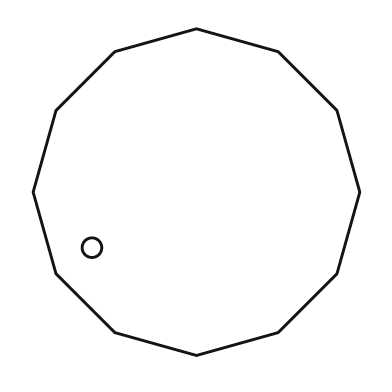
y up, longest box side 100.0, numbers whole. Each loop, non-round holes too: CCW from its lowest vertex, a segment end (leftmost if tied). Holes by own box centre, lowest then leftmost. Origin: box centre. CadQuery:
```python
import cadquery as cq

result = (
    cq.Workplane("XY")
    .moveTo(0.0, -50.0)
    .lineTo(25.0, -43.0)
    .lineTo(43.0, -25.0)
    .lineTo(50.0, 0.0)
    .lineTo(43.0, 25.0)
    .lineTo(25.0, 43.0)
    .lineTo(0.0, 50.0)
    .lineTo(-25.0, 43.0)
    .lineTo(-43.0, 25.0)
    .lineTo(-50.0, 0.0)
    .lineTo(-43.0, -25.0)
    .lineTo(-25.0, -43.0)
    .close()
    .moveTo(-32.0, -17.0)
    .circle(3.0)
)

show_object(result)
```